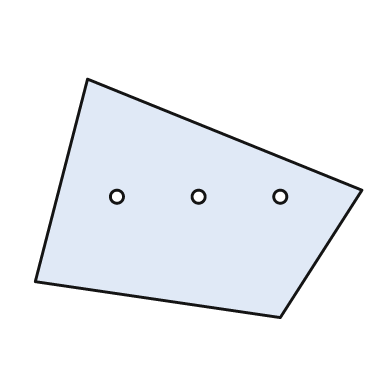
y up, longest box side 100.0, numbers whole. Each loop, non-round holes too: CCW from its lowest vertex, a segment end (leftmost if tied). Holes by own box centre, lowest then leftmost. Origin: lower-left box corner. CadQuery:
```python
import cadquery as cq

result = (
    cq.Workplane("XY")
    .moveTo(75.0, 0.0)
    .lineTo(100.0, 39.0)
    .lineTo(16.0, 73.0)
    .lineTo(0.0, 11.0)
    .close()
    .moveTo(25.0, 37.0)
    .circle(2.0)
    .moveTo(50.0, 37.0)
    .circle(2.0)
    .moveTo(75.0, 37.0)
    .circle(2.0)
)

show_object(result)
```